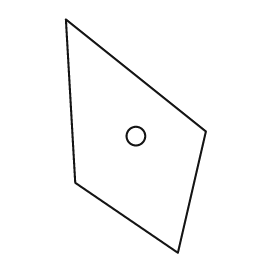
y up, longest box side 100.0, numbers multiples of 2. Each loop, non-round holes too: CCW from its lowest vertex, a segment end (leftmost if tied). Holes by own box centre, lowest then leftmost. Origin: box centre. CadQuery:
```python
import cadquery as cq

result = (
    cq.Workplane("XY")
    .moveTo(18.0, -50.0)
    .lineTo(30.0, 2.0)
    .lineTo(-30.0, 50.0)
    .lineTo(-26.0, -20.0)
    .close()
    .moveTo(0.0, 0.0)
    .circle(4.0)
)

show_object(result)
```